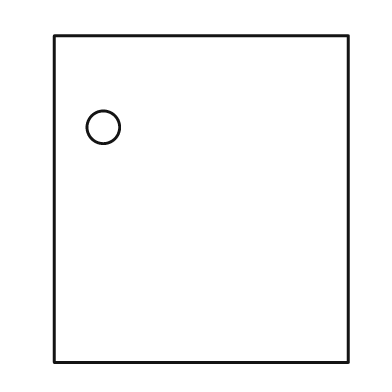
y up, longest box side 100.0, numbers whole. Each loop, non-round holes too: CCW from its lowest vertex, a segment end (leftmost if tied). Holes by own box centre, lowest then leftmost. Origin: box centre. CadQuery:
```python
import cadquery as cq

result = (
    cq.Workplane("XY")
    .moveTo(-45.0, -50.0)
    .lineTo(45.0, -50.0)
    .lineTo(45.0, 50.0)
    .lineTo(-45.0, 50.0)
    .close()
    .moveTo(-30.0, 22.0)
    .circle(5.0)
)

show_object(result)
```